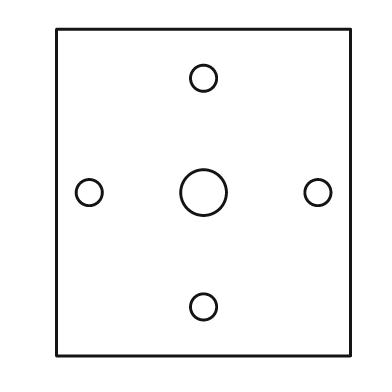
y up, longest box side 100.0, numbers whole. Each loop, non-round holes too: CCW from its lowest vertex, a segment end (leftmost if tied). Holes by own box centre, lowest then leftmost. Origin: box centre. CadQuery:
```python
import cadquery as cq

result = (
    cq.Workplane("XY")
    .moveTo(-45.0, -50.0)
    .lineTo(45.0, -50.0)
    .lineTo(45.0, 50.0)
    .lineTo(-45.0, 50.0)
    .close()
    .moveTo(0.0, -35.0)
    .circle(4.0)
    .moveTo(-35.0, 0.0)
    .circle(4.0)
    .moveTo(0.0, 0.0)
    .circle(7.0)
    .moveTo(35.0, 0.0)
    .circle(4.0)
    .moveTo(0.0, 35.0)
    .circle(4.0)
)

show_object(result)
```